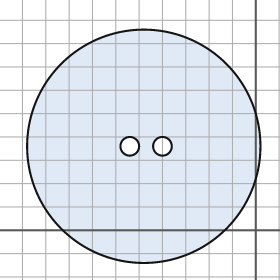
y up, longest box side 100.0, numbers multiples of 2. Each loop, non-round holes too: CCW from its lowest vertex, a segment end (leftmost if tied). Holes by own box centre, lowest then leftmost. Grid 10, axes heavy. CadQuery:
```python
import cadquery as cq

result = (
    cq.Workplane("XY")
    .moveTo(-48.0, 36.0)
    .circle(50.0)
    .moveTo(-54.0, 36.0)
    .circle(4.0)
    .moveTo(-40.0, 36.0)
    .circle(4.0)
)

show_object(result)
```